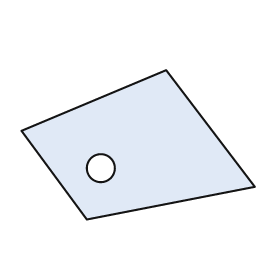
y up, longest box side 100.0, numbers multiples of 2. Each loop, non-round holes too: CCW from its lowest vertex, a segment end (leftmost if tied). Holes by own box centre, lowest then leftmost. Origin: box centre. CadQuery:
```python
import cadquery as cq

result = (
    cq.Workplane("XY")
    .moveTo(-22.0, -32.0)
    .lineTo(50.0, -18.0)
    .lineTo(12.0, 32.0)
    .lineTo(-50.0, 6.0)
    .close()
    .moveTo(-16.0, -10.0)
    .circle(6.0)
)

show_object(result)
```